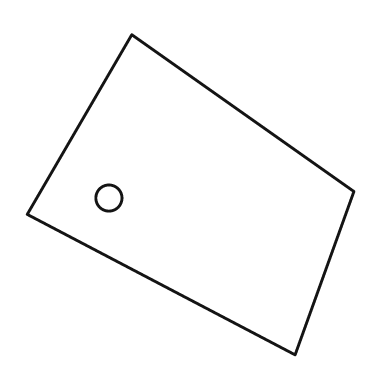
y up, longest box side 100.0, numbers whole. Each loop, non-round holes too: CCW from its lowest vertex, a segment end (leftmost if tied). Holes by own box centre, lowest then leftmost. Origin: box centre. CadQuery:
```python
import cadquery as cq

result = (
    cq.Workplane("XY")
    .moveTo(32.0, -49.0)
    .lineTo(50.0, 1.0)
    .lineTo(-18.0, 49.0)
    .lineTo(-50.0, -6.0)
    .close()
    .moveTo(-25.0, -1.0)
    .circle(4.0)
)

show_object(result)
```